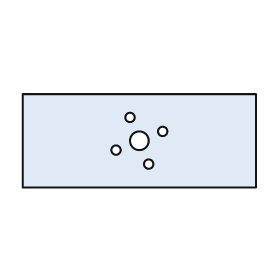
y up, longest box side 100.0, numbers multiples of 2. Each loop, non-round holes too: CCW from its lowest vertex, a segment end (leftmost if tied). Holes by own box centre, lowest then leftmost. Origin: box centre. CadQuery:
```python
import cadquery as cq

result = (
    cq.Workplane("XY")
    .moveTo(-50.0, -20.0)
    .lineTo(50.0, -20.0)
    .lineTo(50.0, 20.0)
    .lineTo(-50.0, 20.0)
    .close()
    .moveTo(4.0, -10.0)
    .circle(2.0)
    .moveTo(-10.0, -4.0)
    .circle(2.0)
    .moveTo(0.0, 0.0)
    .circle(4.0)
    .moveTo(10.0, 4.0)
    .circle(2.0)
    .moveTo(-4.0, 10.0)
    .circle(2.0)
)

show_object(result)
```